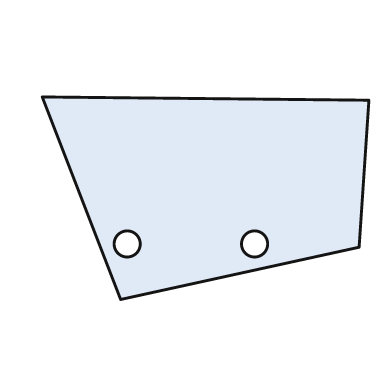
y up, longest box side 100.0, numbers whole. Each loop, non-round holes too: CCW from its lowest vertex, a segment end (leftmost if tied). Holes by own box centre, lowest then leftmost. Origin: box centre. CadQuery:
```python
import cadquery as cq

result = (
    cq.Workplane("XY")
    .moveTo(-26.0, -31.0)
    .lineTo(47.0, -15.0)
    .lineTo(50.0, 30.0)
    .lineTo(-50.0, 31.0)
    .close()
    .moveTo(-24.0, -14.0)
    .circle(4.0)
    .moveTo(15.0, -14.0)
    .circle(4.0)
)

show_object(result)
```